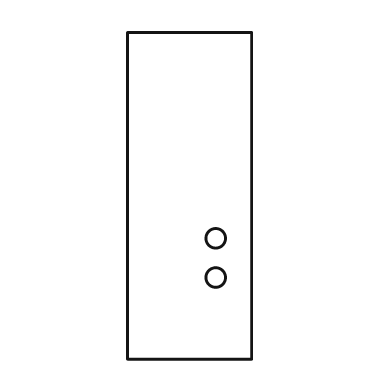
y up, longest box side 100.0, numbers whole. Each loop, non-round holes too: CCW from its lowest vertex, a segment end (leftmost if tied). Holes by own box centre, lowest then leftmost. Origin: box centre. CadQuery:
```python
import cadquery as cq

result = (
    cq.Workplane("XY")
    .moveTo(-19.0, -50.0)
    .lineTo(19.0, -50.0)
    .lineTo(19.0, 50.0)
    .lineTo(-19.0, 50.0)
    .close()
    .moveTo(8.0, -25.0)
    .circle(3.0)
    .moveTo(8.0, -13.0)
    .circle(3.0)
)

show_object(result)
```